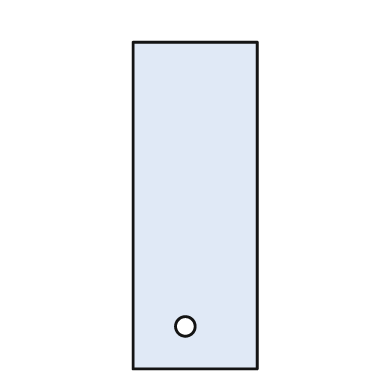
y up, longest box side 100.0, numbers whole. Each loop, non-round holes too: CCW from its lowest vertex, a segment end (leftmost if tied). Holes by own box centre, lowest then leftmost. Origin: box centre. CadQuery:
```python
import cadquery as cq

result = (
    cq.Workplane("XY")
    .moveTo(-19.0, -50.0)
    .lineTo(19.0, -50.0)
    .lineTo(19.0, 50.0)
    .lineTo(-19.0, 50.0)
    .close()
    .moveTo(-3.0, -37.0)
    .circle(3.0)
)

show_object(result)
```